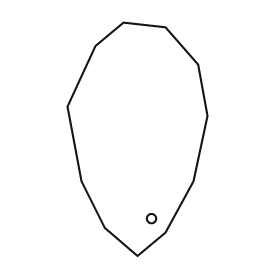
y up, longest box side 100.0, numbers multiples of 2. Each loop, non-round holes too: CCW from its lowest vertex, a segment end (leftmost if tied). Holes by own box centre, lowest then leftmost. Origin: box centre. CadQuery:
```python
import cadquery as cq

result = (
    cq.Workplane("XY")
    .moveTo(0.0, -50.0)
    .lineTo(12.0, -40.0)
    .lineTo(24.0, -18.0)
    .lineTo(30.0, 10.0)
    .lineTo(26.0, 32.0)
    .lineTo(12.0, 48.0)
    .lineTo(-6.0, 50.0)
    .lineTo(-18.0, 40.0)
    .lineTo(-30.0, 14.0)
    .lineTo(-24.0, -18.0)
    .lineTo(-14.0, -38.0)
    .close()
    .moveTo(6.0, -34.0)
    .circle(2.0)
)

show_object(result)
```